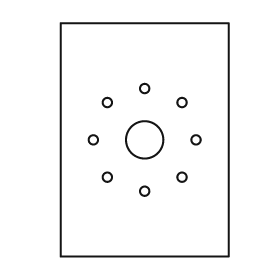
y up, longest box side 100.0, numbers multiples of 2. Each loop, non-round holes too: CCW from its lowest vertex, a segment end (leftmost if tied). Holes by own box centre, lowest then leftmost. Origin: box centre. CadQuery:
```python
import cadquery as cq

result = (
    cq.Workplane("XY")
    .moveTo(-36.0, -50.0)
    .lineTo(36.0, -50.0)
    .lineTo(36.0, 50.0)
    .lineTo(-36.0, 50.0)
    .close()
    .moveTo(0.0, -22.0)
    .circle(2.0)
    .moveTo(-16.0, -16.0)
    .circle(2.0)
    .moveTo(16.0, -16.0)
    .circle(2.0)
    .moveTo(-22.0, 0.0)
    .circle(2.0)
    .moveTo(0.0, 0.0)
    .circle(8.0)
    .moveTo(22.0, 0.0)
    .circle(2.0)
    .moveTo(-16.0, 16.0)
    .circle(2.0)
    .moveTo(16.0, 16.0)
    .circle(2.0)
    .moveTo(0.0, 22.0)
    .circle(2.0)
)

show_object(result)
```